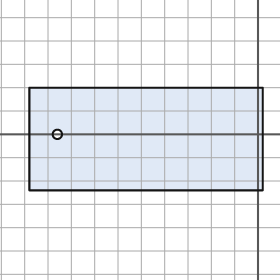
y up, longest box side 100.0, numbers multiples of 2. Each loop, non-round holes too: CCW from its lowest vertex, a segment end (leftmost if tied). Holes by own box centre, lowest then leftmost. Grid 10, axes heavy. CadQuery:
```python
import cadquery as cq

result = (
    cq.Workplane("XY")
    .moveTo(-98.0, -24.0)
    .lineTo(2.0, -24.0)
    .lineTo(2.0, 20.0)
    .lineTo(-98.0, 20.0)
    .close()
    .moveTo(-86.0, 0.0)
    .circle(2.0)
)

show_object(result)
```